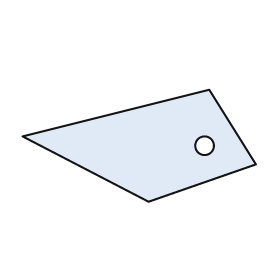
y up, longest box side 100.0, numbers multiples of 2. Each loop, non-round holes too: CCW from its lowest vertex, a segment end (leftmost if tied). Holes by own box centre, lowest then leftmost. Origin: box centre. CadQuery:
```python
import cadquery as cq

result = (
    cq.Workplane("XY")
    .moveTo(4.0, -24.0)
    .lineTo(50.0, -8.0)
    .lineTo(30.0, 24.0)
    .lineTo(-50.0, 4.0)
    .close()
    .moveTo(28.0, 0.0)
    .circle(4.0)
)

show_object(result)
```